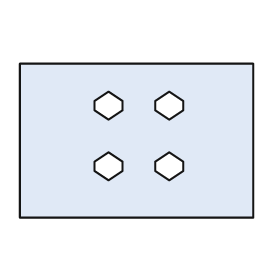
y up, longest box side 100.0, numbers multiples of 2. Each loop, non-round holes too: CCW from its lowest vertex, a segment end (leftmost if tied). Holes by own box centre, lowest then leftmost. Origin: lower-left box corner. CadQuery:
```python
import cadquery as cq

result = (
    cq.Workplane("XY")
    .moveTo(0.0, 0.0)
    .lineTo(100.0, 0.0)
    .lineTo(100.0, 66.0)
    .lineTo(0.0, 66.0)
    .close()
    .moveTo(38.0, 16.0)
    .lineTo(44.0, 20.0)
    .lineTo(44.0, 24.0)
    .lineTo(38.0, 28.0)
    .lineTo(32.0, 24.0)
    .lineTo(32.0, 20.0)
    .close()
    .moveTo(64.0, 16.0)
    .lineTo(70.0, 20.0)
    .lineTo(70.0, 24.0)
    .lineTo(64.0, 28.0)
    .lineTo(58.0, 24.0)
    .lineTo(58.0, 20.0)
    .close()
    .moveTo(38.0, 42.0)
    .lineTo(44.0, 46.0)
    .lineTo(44.0, 50.0)
    .lineTo(38.0, 54.0)
    .lineTo(32.0, 50.0)
    .lineTo(32.0, 46.0)
    .close()
    .moveTo(64.0, 42.0)
    .lineTo(70.0, 46.0)
    .lineTo(70.0, 50.0)
    .lineTo(64.0, 54.0)
    .lineTo(58.0, 50.0)
    .lineTo(58.0, 46.0)
    .close()
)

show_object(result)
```